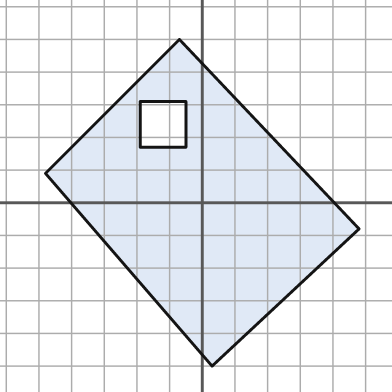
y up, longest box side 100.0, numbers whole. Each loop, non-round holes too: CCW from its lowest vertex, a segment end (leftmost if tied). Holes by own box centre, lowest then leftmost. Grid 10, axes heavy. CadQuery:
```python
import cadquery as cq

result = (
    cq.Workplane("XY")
    .moveTo(3.0, -50.0)
    .lineTo(48.0, -8.0)
    .lineTo(-7.0, 50.0)
    .lineTo(-48.0, 9.0)
    .close()
    .moveTo(-19.0, 17.0)
    .lineTo(-5.0, 17.0)
    .lineTo(-5.0, 31.0)
    .lineTo(-19.0, 31.0)
    .close()
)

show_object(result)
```